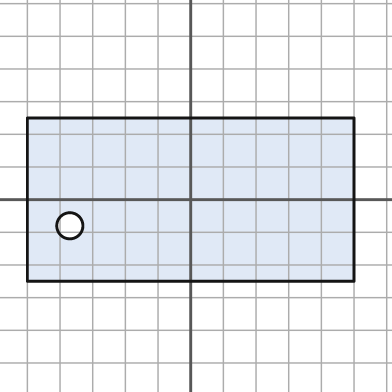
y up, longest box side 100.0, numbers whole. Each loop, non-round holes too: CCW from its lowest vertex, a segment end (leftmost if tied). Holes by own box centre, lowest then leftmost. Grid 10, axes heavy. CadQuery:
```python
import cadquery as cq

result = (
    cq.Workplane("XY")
    .moveTo(-50.0, -25.0)
    .lineTo(50.0, -25.0)
    .lineTo(50.0, 25.0)
    .lineTo(-50.0, 25.0)
    .close()
    .moveTo(-37.0, -8.0)
    .circle(4.0)
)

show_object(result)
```